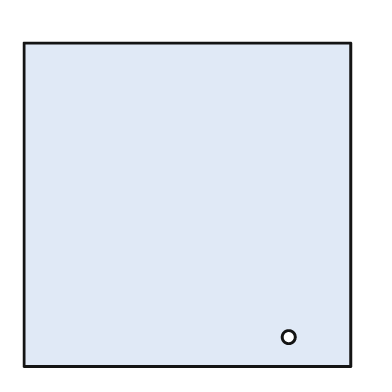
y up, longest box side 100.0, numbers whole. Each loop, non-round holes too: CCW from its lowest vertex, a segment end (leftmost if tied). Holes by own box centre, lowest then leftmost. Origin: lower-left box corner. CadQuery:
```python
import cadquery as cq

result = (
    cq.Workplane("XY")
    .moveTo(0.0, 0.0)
    .lineTo(100.0, 0.0)
    .lineTo(100.0, 99.0)
    .lineTo(0.0, 99.0)
    .close()
    .moveTo(81.0, 9.0)
    .circle(2.0)
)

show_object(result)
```